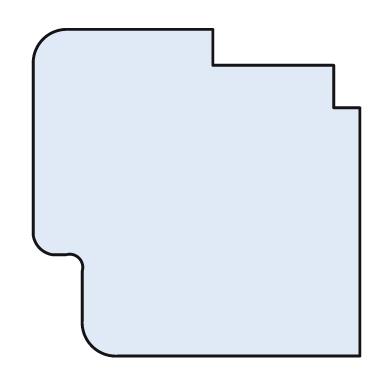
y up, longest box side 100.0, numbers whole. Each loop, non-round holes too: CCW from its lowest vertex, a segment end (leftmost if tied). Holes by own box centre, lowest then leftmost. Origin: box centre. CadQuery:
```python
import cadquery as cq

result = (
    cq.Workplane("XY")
    .moveTo(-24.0, -50.0)
    .lineTo(50.0, -50.0)
    .lineTo(50.0, 26.0)
    .lineTo(42.0, 26.0)
    .lineTo(42.0, 39.0)
    .lineTo(5.0, 39.0)
    .lineTo(5.0, 50.0)
    .lineTo(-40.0, 50.0)
    .threePointArc((-47.0, 47.0), (-50.0, 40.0))
    .lineTo(-50.0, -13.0)
    .threePointArc((-48.0, -17.0), (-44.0, -19.0))
    .lineTo(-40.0, -19.0)
    .threePointArc((-36.0, -20.0), (-35.0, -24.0))
    .lineTo(-35.0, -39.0)
    .threePointArc((-32.0, -47.0), (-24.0, -50.0))
    .close()
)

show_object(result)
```